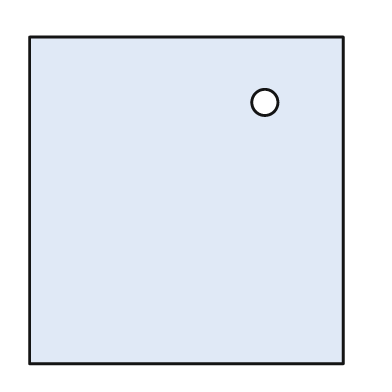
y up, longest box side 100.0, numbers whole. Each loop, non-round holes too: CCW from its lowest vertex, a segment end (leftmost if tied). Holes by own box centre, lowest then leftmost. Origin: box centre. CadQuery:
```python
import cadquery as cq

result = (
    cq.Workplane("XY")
    .moveTo(-48.0, -50.0)
    .lineTo(48.0, -50.0)
    .lineTo(48.0, 50.0)
    .lineTo(-48.0, 50.0)
    .close()
    .moveTo(24.0, 30.0)
    .circle(4.0)
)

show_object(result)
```